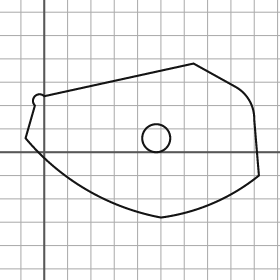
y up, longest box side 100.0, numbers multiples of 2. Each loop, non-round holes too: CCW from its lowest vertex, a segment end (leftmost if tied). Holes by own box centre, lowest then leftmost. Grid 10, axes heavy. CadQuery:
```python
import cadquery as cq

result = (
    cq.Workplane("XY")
    .moveTo(50.0, -28.0)
    .threePointArc((72.0, -22.0), (92.0, -10.0))
    .lineTo(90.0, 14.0)
    .threePointArc((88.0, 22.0), (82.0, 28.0))
    .lineTo(64.0, 38.0)
    .lineTo(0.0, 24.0)
    .threePointArc((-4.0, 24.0), (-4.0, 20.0))
    .lineTo(-8.0, 6.0)
    .threePointArc((18.0, -16.0), (50.0, -28.0))
    .close()
    .moveTo(48.0, 6.0)
    .circle(6.0)
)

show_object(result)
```